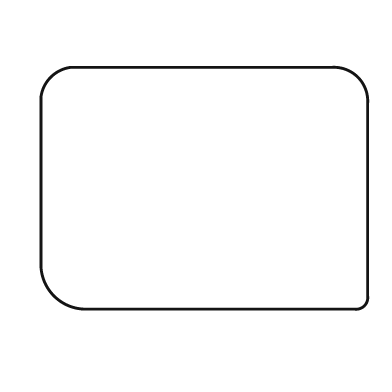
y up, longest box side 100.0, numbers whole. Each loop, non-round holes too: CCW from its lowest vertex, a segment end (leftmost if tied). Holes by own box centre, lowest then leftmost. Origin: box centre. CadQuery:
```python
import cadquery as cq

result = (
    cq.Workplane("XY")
    .moveTo(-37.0, -37.0)
    .lineTo(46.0, -37.0)
    .threePointArc((49.0, -36.0), (50.0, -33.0))
    .lineTo(50.0, 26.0)
    .threePointArc((47.0, 34.0), (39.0, 37.0))
    .lineTo(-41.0, 37.0)
    .threePointArc((-47.0, 34.0), (-50.0, 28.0))
    .lineTo(-50.0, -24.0)
    .threePointArc((-46.0, -33.0), (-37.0, -37.0))
    .close()
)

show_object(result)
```